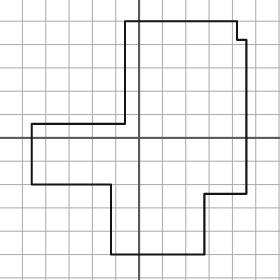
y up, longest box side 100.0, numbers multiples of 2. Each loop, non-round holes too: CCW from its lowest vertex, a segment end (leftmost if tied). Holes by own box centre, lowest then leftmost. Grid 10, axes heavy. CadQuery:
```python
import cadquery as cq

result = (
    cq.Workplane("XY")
    .moveTo(-12.0, -50.0)
    .lineTo(28.0, -50.0)
    .lineTo(28.0, -24.0)
    .lineTo(46.0, -24.0)
    .lineTo(46.0, 42.0)
    .lineTo(42.0, 42.0)
    .lineTo(42.0, 50.0)
    .lineTo(-6.0, 50.0)
    .lineTo(-6.0, 6.0)
    .lineTo(-46.0, 6.0)
    .lineTo(-46.0, -20.0)
    .lineTo(-12.0, -20.0)
    .close()
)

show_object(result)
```